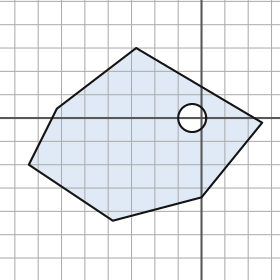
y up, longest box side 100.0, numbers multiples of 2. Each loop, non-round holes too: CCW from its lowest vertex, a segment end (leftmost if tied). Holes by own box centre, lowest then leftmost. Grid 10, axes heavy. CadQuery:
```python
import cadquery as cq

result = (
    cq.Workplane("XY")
    .moveTo(-38.0, -44.0)
    .lineTo(0.0, -34.0)
    .lineTo(26.0, -2.0)
    .lineTo(-28.0, 30.0)
    .lineTo(-62.0, 4.0)
    .lineTo(-74.0, -20.0)
    .close()
    .moveTo(-4.0, 0.0)
    .circle(6.0)
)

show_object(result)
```